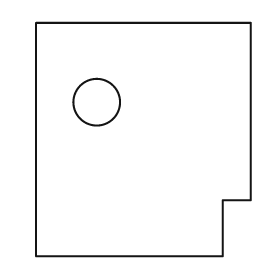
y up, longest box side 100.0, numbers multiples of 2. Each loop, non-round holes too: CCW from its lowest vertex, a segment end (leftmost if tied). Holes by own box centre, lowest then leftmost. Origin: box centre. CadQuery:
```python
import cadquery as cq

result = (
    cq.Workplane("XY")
    .moveTo(-46.0, -50.0)
    .lineTo(34.0, -50.0)
    .lineTo(34.0, -26.0)
    .lineTo(46.0, -26.0)
    .lineTo(46.0, 50.0)
    .lineTo(-46.0, 50.0)
    .close()
    .moveTo(-20.0, 16.0)
    .circle(10.0)
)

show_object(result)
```